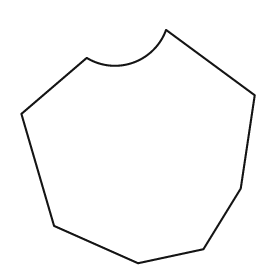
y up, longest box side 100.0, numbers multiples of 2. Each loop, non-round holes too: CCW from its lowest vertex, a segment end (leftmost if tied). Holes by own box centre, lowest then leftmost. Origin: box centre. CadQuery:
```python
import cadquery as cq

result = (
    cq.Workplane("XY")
    .moveTo(0.0, -50.0)
    .lineTo(28.0, -44.0)
    .lineTo(44.0, -18.0)
    .lineTo(50.0, 22.0)
    .lineTo(12.0, 50.0)
    .threePointArc((-2.0, 36.0), (-22.0, 38.0))
    .lineTo(-50.0, 14.0)
    .lineTo(-36.0, -34.0)
    .close()
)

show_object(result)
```